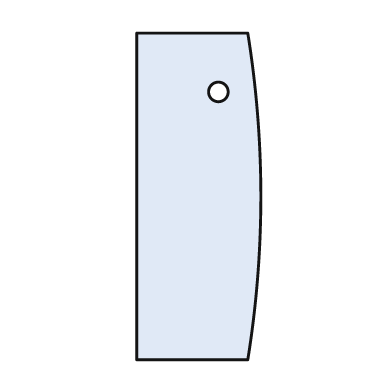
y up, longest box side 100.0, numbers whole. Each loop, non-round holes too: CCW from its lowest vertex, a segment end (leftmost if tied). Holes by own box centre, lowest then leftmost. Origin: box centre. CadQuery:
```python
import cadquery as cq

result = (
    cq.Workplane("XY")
    .moveTo(-19.0, -50.0)
    .lineTo(15.0, -50.0)
    .threePointArc((19.0, 0.0), (15.0, 50.0))
    .lineTo(-19.0, 50.0)
    .close()
    .moveTo(6.0, 32.0)
    .circle(3.0)
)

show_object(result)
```